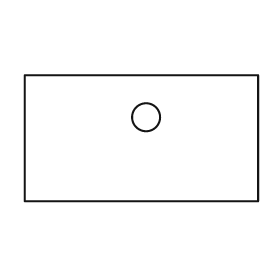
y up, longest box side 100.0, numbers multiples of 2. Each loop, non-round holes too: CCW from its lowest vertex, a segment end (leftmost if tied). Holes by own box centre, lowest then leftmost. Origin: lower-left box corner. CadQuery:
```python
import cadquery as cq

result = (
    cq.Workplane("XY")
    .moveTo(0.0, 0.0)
    .lineTo(100.0, 0.0)
    .lineTo(100.0, 54.0)
    .lineTo(0.0, 54.0)
    .close()
    .moveTo(52.0, 36.0)
    .circle(6.0)
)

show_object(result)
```